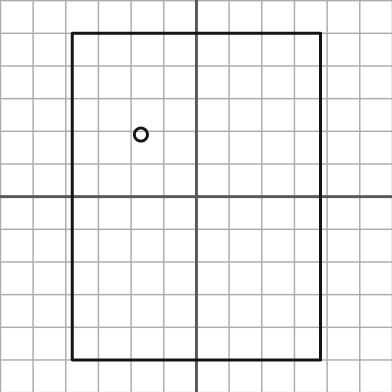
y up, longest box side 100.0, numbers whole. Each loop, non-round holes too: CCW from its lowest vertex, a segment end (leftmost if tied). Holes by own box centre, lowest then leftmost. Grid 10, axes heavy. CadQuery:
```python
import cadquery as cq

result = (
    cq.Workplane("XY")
    .moveTo(-38.0, -50.0)
    .lineTo(38.0, -50.0)
    .lineTo(38.0, 50.0)
    .lineTo(-38.0, 50.0)
    .close()
    .moveTo(-17.0, 19.0)
    .circle(2.0)
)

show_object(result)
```